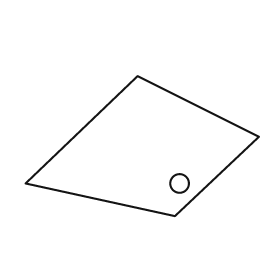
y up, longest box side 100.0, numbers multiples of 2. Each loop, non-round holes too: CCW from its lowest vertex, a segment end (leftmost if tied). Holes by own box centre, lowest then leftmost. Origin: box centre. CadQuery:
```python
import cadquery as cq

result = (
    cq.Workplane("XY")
    .moveTo(14.0, -30.0)
    .lineTo(50.0, 4.0)
    .lineTo(-2.0, 30.0)
    .lineTo(-50.0, -16.0)
    .close()
    .moveTo(16.0, -16.0)
    .circle(4.0)
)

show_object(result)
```